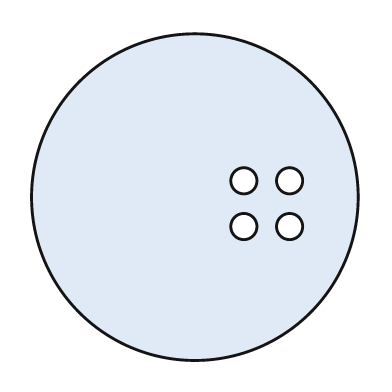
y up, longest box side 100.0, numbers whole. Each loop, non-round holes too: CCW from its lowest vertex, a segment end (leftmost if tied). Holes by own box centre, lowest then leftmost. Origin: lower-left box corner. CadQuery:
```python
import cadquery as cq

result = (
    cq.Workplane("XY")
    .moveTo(50.0, 50.0)
    .circle(50.0)
    .moveTo(65.0, 41.0)
    .circle(4.0)
    .moveTo(79.0, 41.0)
    .circle(4.0)
    .moveTo(65.0, 55.0)
    .circle(4.0)
    .moveTo(79.0, 55.0)
    .circle(4.0)
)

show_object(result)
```